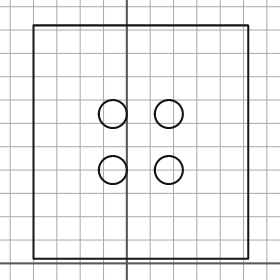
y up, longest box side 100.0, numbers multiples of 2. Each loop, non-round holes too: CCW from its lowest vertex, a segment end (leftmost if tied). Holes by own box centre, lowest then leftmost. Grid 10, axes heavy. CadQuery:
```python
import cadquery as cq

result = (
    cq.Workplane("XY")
    .moveTo(-40.0, 2.0)
    .lineTo(52.0, 2.0)
    .lineTo(52.0, 102.0)
    .lineTo(-40.0, 102.0)
    .close()
    .moveTo(-6.0, 40.0)
    .circle(6.0)
    .moveTo(18.0, 40.0)
    .circle(6.0)
    .moveTo(-6.0, 64.0)
    .circle(6.0)
    .moveTo(18.0, 64.0)
    .circle(6.0)
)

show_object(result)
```